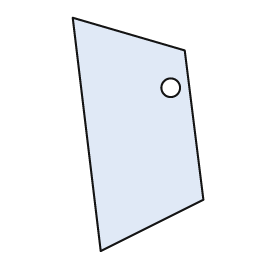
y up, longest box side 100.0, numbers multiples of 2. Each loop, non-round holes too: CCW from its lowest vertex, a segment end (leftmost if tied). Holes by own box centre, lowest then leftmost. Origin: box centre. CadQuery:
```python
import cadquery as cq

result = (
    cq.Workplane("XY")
    .moveTo(-16.0, -50.0)
    .lineTo(28.0, -28.0)
    .lineTo(20.0, 36.0)
    .lineTo(-28.0, 50.0)
    .close()
    .moveTo(14.0, 20.0)
    .circle(4.0)
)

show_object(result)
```